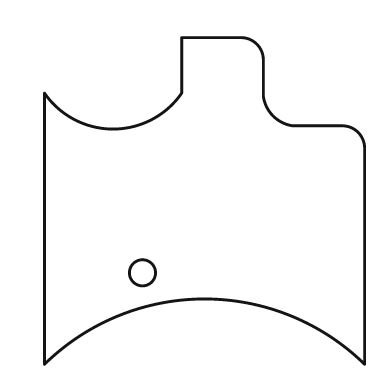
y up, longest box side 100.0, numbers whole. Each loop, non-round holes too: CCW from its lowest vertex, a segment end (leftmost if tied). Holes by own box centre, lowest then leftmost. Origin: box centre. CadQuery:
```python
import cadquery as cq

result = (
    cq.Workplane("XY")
    .moveTo(-49.0, -50.0)
    .threePointArc((0.0, -30.0), (49.0, -50.0))
    .lineTo(49.0, 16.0)
    .threePointArc((47.0, 21.0), (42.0, 23.0))
    .lineTo(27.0, 23.0)
    .threePointArc((21.0, 26.0), (18.0, 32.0))
    .lineTo(18.0, 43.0)
    .threePointArc((16.0, 48.0), (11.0, 50.0))
    .lineTo(-7.0, 50.0)
    .lineTo(-7.0, 33.0)
    .threePointArc((-28.0, 22.0), (-49.0, 33.0))
    .close()
    .moveTo(-19.0, -22.0)
    .circle(4.0)
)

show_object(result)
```